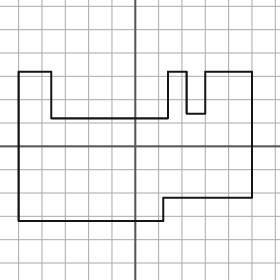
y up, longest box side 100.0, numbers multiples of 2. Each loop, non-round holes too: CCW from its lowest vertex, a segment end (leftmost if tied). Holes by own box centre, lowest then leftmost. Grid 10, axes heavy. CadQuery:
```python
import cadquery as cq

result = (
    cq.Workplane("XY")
    .moveTo(-50.0, -32.0)
    .lineTo(12.0, -32.0)
    .lineTo(12.0, -22.0)
    .lineTo(50.0, -22.0)
    .lineTo(50.0, 32.0)
    .lineTo(30.0, 32.0)
    .lineTo(30.0, 14.0)
    .lineTo(22.0, 14.0)
    .lineTo(22.0, 32.0)
    .lineTo(14.0, 32.0)
    .lineTo(14.0, 12.0)
    .lineTo(-36.0, 12.0)
    .lineTo(-36.0, 32.0)
    .lineTo(-50.0, 32.0)
    .close()
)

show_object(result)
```